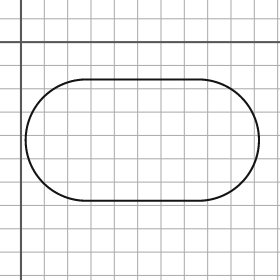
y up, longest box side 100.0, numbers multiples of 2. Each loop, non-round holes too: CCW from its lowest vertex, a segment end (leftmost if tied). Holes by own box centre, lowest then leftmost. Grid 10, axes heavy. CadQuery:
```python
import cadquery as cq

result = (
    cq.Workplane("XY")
    .moveTo(28.0, -68.0)
    .lineTo(76.0, -68.0)
    .threePointArc((102.0, -42.0), (76.0, -16.0))
    .lineTo(28.0, -16.0)
    .threePointArc((2.0, -42.0), (28.0, -68.0))
    .close()
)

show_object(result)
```